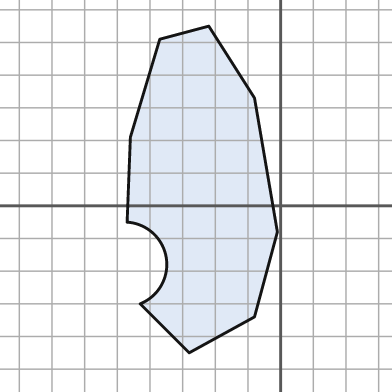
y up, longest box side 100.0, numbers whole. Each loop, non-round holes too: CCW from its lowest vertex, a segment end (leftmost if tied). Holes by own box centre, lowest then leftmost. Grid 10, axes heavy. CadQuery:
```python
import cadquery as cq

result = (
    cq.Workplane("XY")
    .moveTo(-28.0, -45.0)
    .lineTo(-8.0, -34.0)
    .lineTo(-1.0, -8.0)
    .lineTo(-8.0, 33.0)
    .lineTo(-22.0, 55.0)
    .lineTo(-37.0, 51.0)
    .lineTo(-46.0, 21.0)
    .lineTo(-47.0, -5.0)
    .threePointArc((-35.0, -16.0), (-43.0, -30.0))
    .close()
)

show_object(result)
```